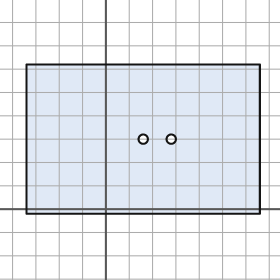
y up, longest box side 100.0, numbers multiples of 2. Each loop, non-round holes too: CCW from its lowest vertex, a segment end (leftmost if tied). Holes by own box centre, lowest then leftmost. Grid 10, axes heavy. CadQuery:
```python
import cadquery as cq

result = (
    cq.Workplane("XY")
    .moveTo(-34.0, -2.0)
    .lineTo(66.0, -2.0)
    .lineTo(66.0, 62.0)
    .lineTo(-34.0, 62.0)
    .close()
    .moveTo(16.0, 30.0)
    .circle(2.0)
    .moveTo(28.0, 30.0)
    .circle(2.0)
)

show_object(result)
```